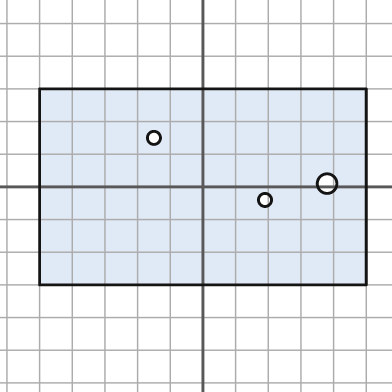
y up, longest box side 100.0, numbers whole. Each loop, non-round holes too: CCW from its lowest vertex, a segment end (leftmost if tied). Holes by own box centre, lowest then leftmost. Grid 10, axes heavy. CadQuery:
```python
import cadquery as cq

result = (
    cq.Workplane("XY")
    .moveTo(-50.0, -30.0)
    .lineTo(50.0, -30.0)
    .lineTo(50.0, 30.0)
    .lineTo(-50.0, 30.0)
    .close()
    .moveTo(19.0, -4.0)
    .circle(2.0)
    .moveTo(38.0, 1.0)
    .circle(3.0)
    .moveTo(-15.0, 15.0)
    .circle(2.0)
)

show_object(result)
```